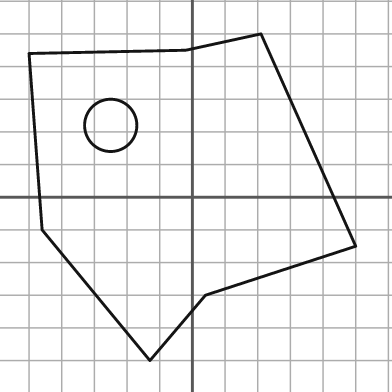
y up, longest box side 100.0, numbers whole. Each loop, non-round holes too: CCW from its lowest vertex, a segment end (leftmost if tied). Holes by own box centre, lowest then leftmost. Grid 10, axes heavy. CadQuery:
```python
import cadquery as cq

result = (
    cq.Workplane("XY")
    .moveTo(-13.0, -50.0)
    .lineTo(4.0, -30.0)
    .lineTo(50.0, -15.0)
    .lineTo(21.0, 50.0)
    .lineTo(-2.0, 45.0)
    .lineTo(-50.0, 44.0)
    .lineTo(-46.0, -10.0)
    .close()
    .moveTo(-25.0, 22.0)
    .circle(8.0)
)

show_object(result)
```